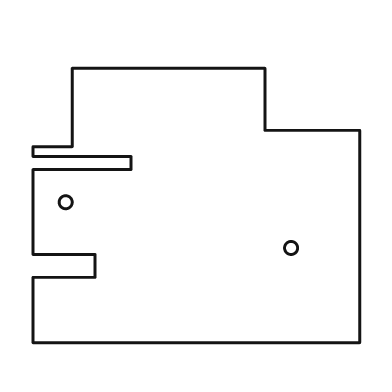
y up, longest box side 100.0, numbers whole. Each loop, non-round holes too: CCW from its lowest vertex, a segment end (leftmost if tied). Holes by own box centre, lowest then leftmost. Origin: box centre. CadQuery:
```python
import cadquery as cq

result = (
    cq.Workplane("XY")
    .moveTo(-50.0, -42.0)
    .lineTo(50.0, -42.0)
    .lineTo(50.0, 23.0)
    .lineTo(21.0, 23.0)
    .lineTo(21.0, 42.0)
    .lineTo(-38.0, 42.0)
    .lineTo(-38.0, 18.0)
    .lineTo(-50.0, 18.0)
    .lineTo(-50.0, 15.0)
    .lineTo(-20.0, 15.0)
    .lineTo(-20.0, 11.0)
    .lineTo(-50.0, 11.0)
    .lineTo(-50.0, -15.0)
    .lineTo(-31.0, -15.0)
    .lineTo(-31.0, -22.0)
    .lineTo(-50.0, -22.0)
    .close()
    .moveTo(29.0, -13.0)
    .circle(2.0)
    .moveTo(-40.0, 1.0)
    .circle(2.0)
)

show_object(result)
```